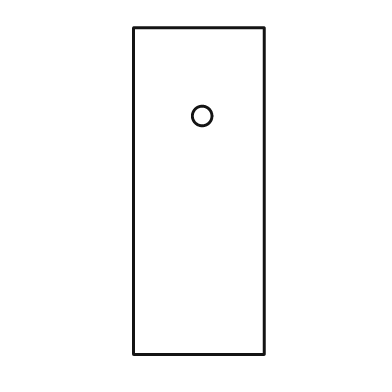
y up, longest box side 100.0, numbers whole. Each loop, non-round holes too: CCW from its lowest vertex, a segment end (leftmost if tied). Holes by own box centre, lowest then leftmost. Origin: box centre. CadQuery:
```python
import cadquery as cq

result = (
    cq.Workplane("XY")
    .moveTo(-20.0, -50.0)
    .lineTo(20.0, -50.0)
    .lineTo(20.0, 50.0)
    .lineTo(-20.0, 50.0)
    .close()
    .moveTo(1.0, 23.0)
    .circle(3.0)
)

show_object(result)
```